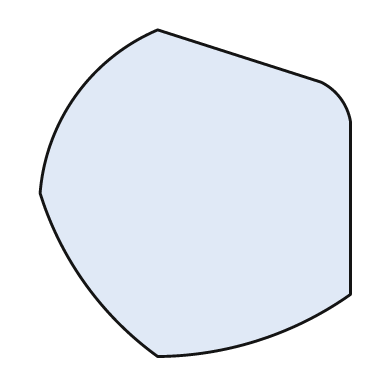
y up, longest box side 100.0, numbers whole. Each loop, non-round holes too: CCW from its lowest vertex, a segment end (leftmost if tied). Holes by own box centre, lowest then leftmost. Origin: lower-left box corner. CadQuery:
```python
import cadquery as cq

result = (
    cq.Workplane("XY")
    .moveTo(36.0, 0.0)
    .threePointArc((67.0, 5.0), (95.0, 19.0))
    .lineTo(95.0, 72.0)
    .threePointArc((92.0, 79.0), (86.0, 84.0))
    .lineTo(36.0, 100.0)
    .threePointArc((11.0, 80.0), (0.0, 50.0))
    .threePointArc((14.0, 22.0), (36.0, 0.0))
    .close()
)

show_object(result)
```